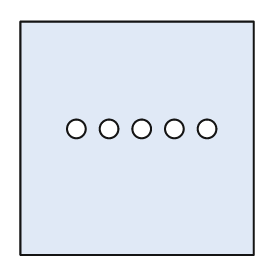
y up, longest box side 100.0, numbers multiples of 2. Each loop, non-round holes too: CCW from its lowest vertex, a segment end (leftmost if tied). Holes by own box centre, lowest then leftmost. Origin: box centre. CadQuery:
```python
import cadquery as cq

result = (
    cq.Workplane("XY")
    .moveTo(-50.0, -50.0)
    .lineTo(50.0, -50.0)
    .lineTo(50.0, 50.0)
    .lineTo(-50.0, 50.0)
    .close()
    .moveTo(-26.0, 4.0)
    .circle(4.0)
    .moveTo(-12.0, 4.0)
    .circle(4.0)
    .moveTo(2.0, 4.0)
    .circle(4.0)
    .moveTo(16.0, 4.0)
    .circle(4.0)
    .moveTo(30.0, 4.0)
    .circle(4.0)
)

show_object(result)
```